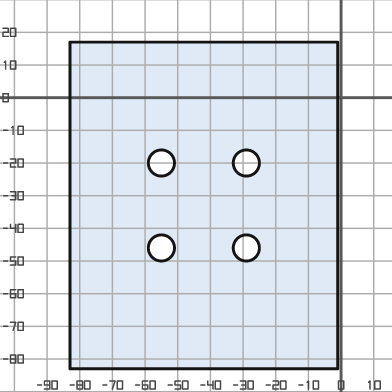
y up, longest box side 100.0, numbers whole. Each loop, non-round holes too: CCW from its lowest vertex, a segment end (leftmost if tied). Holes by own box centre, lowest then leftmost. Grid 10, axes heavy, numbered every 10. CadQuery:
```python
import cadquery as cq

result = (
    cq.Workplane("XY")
    .moveTo(-83.0, -83.0)
    .lineTo(-1.0, -83.0)
    .lineTo(-1.0, 17.0)
    .lineTo(-83.0, 17.0)
    .close()
    .moveTo(-55.0, -46.0)
    .circle(4.0)
    .moveTo(-29.0, -46.0)
    .circle(4.0)
    .moveTo(-55.0, -20.0)
    .circle(4.0)
    .moveTo(-29.0, -20.0)
    .circle(4.0)
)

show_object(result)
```